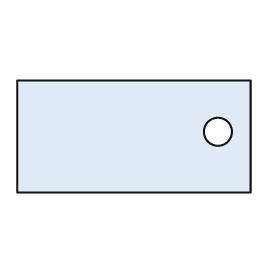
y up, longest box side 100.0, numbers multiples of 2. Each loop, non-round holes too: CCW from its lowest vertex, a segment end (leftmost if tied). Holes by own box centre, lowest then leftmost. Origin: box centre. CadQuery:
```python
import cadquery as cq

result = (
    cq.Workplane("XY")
    .moveTo(-50.0, -24.0)
    .lineTo(50.0, -24.0)
    .lineTo(50.0, 24.0)
    .lineTo(-50.0, 24.0)
    .close()
    .moveTo(36.0, 2.0)
    .circle(6.0)
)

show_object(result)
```